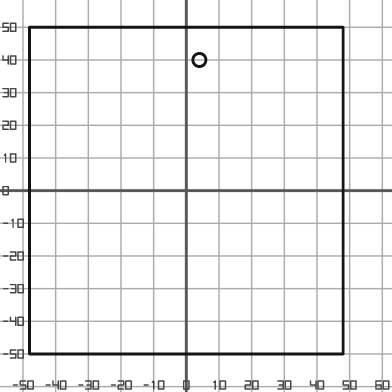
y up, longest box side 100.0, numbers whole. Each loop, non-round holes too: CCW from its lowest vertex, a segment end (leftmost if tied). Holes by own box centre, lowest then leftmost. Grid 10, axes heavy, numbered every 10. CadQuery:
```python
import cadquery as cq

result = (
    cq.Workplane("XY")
    .moveTo(-48.0, -50.0)
    .lineTo(48.0, -50.0)
    .lineTo(48.0, 50.0)
    .lineTo(-48.0, 50.0)
    .close()
    .moveTo(4.0, 40.0)
    .circle(2.0)
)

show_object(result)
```